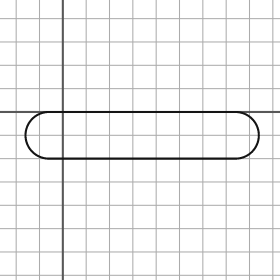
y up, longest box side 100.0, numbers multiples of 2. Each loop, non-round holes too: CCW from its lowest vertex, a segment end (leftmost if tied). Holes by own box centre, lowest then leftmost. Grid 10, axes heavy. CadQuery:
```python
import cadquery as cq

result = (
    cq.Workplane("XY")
    .moveTo(-6.0, -20.0)
    .lineTo(74.0, -20.0)
    .threePointArc((84.0, -10.0), (74.0, 0.0))
    .lineTo(-6.0, 0.0)
    .threePointArc((-16.0, -10.0), (-6.0, -20.0))
    .close()
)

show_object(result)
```